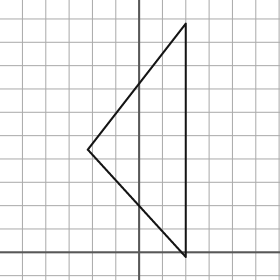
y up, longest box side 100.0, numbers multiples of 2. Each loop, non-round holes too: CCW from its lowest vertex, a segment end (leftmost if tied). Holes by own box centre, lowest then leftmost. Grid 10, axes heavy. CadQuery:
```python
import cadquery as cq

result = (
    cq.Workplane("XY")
    .moveTo(20.0, -2.0)
    .lineTo(20.0, 98.0)
    .lineTo(-22.0, 44.0)
    .close()
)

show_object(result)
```